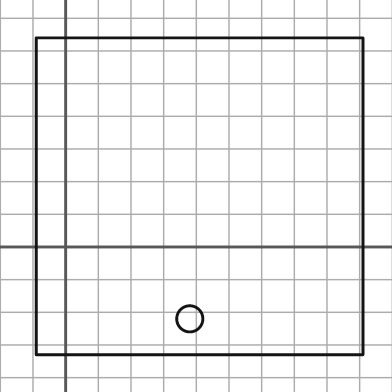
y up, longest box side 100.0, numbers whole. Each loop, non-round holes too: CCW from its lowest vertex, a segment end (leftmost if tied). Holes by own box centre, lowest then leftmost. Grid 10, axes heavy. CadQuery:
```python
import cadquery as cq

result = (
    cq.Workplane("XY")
    .moveTo(-9.0, -33.0)
    .lineTo(91.0, -33.0)
    .lineTo(91.0, 64.0)
    .lineTo(-9.0, 64.0)
    .close()
    .moveTo(38.0, -22.0)
    .circle(4.0)
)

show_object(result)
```